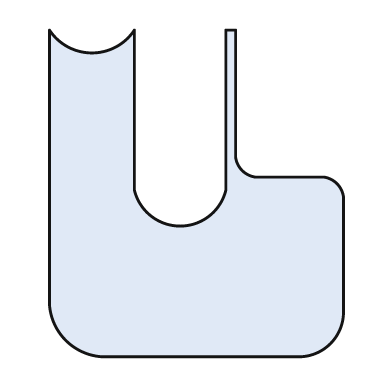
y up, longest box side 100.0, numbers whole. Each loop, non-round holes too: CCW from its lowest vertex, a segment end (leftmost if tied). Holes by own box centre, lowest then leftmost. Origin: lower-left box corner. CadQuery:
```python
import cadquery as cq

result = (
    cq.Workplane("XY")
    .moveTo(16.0, 0.0)
    .lineTo(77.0, 0.0)
    .threePointArc((86.0, 4.0), (90.0, 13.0))
    .lineTo(90.0, 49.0)
    .threePointArc((88.0, 53.0), (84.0, 55.0))
    .lineTo(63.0, 55.0)
    .threePointArc((59.0, 57.0), (57.0, 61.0))
    .lineTo(57.0, 100.0)
    .lineTo(54.0, 100.0)
    .lineTo(54.0, 51.0)
    .threePointArc((40.0, 40.0), (26.0, 51.0))
    .lineTo(26.0, 100.0)
    .threePointArc((13.0, 93.0), (0.0, 100.0))
    .lineTo(0.0, 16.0)
    .threePointArc((5.0, 5.0), (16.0, 0.0))
    .close()
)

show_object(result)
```